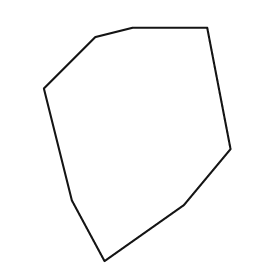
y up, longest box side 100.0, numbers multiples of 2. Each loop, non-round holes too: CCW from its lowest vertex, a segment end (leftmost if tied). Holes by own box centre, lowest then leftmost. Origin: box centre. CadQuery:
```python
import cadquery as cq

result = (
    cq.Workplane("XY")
    .moveTo(-14.0, -50.0)
    .lineTo(20.0, -26.0)
    .lineTo(40.0, -2.0)
    .lineTo(30.0, 50.0)
    .lineTo(-2.0, 50.0)
    .lineTo(-18.0, 46.0)
    .lineTo(-40.0, 24.0)
    .lineTo(-28.0, -24.0)
    .close()
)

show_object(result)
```